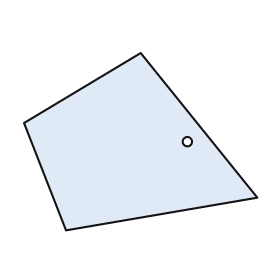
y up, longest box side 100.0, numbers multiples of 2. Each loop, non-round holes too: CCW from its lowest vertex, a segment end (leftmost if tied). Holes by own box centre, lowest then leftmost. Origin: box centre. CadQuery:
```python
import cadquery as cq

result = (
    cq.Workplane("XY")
    .moveTo(-32.0, -38.0)
    .lineTo(50.0, -24.0)
    .lineTo(0.0, 38.0)
    .lineTo(-50.0, 8.0)
    .close()
    .moveTo(20.0, 0.0)
    .circle(2.0)
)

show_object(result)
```